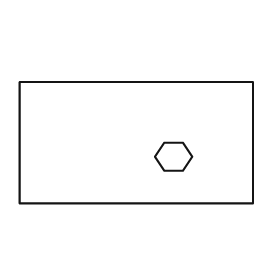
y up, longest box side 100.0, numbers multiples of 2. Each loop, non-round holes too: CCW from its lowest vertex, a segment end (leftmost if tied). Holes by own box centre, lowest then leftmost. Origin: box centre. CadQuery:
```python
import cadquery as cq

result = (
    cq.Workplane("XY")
    .moveTo(-50.0, -26.0)
    .lineTo(50.0, -26.0)
    .lineTo(50.0, 26.0)
    .lineTo(-50.0, 26.0)
    .close()
    .moveTo(12.0, -12.0)
    .lineTo(20.0, -12.0)
    .lineTo(24.0, -6.0)
    .lineTo(20.0, 0.0)
    .lineTo(12.0, 0.0)
    .lineTo(8.0, -6.0)
    .close()
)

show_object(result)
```